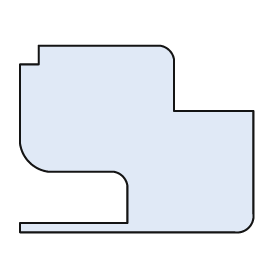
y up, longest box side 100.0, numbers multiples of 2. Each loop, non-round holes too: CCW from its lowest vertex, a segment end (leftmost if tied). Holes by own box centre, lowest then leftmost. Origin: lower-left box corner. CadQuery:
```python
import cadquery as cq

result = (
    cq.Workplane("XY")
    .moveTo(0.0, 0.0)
    .lineTo(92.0, 0.0)
    .threePointArc((98.0, 2.0), (100.0, 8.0))
    .lineTo(100.0, 52.0)
    .lineTo(66.0, 52.0)
    .lineTo(66.0, 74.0)
    .threePointArc((64.0, 78.0), (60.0, 80.0))
    .lineTo(8.0, 80.0)
    .lineTo(8.0, 72.0)
    .lineTo(0.0, 72.0)
    .lineTo(0.0, 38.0)
    .threePointArc((4.0, 30.0), (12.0, 26.0))
    .lineTo(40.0, 26.0)
    .threePointArc((44.0, 24.0), (46.0, 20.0))
    .lineTo(46.0, 4.0)
    .lineTo(0.0, 4.0)
    .close()
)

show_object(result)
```